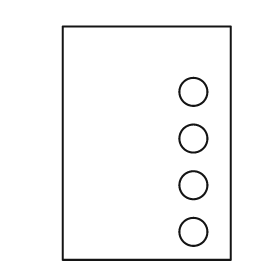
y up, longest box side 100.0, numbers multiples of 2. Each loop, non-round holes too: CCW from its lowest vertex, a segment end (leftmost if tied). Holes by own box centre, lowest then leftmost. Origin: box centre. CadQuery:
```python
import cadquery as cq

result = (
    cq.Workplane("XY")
    .moveTo(-36.0, -50.0)
    .lineTo(36.0, -50.0)
    .lineTo(36.0, 50.0)
    .lineTo(-36.0, 50.0)
    .close()
    .moveTo(20.0, -38.0)
    .circle(6.0)
    .moveTo(20.0, -18.0)
    .circle(6.0)
    .moveTo(20.0, 2.0)
    .circle(6.0)
    .moveTo(20.0, 22.0)
    .circle(6.0)
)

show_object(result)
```